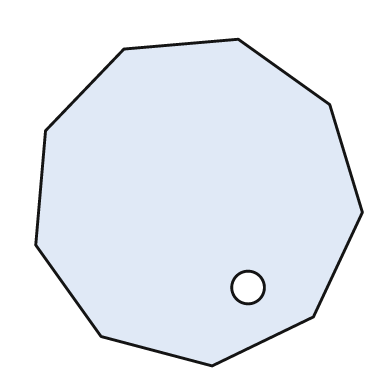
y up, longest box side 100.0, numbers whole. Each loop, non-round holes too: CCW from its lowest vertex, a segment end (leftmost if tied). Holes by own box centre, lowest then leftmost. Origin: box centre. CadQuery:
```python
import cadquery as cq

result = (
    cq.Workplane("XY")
    .moveTo(4.0, -50.0)
    .lineTo(35.0, -35.0)
    .lineTo(50.0, -3.0)
    .lineTo(40.0, 30.0)
    .lineTo(12.0, 50.0)
    .lineTo(-23.0, 47.0)
    .lineTo(-47.0, 22.0)
    .lineTo(-50.0, -13.0)
    .lineTo(-30.0, -41.0)
    .close()
    .moveTo(15.0, -26.0)
    .circle(5.0)
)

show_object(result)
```